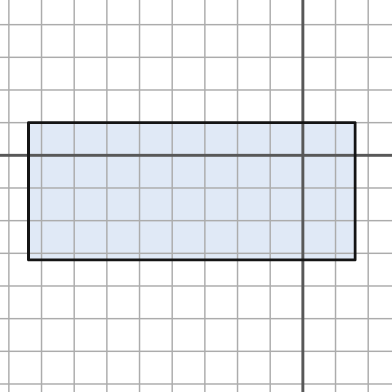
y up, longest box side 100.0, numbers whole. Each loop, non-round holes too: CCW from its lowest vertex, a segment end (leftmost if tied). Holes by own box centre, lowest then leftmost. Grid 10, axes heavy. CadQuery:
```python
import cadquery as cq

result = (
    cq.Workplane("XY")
    .moveTo(-84.0, -32.0)
    .lineTo(16.0, -32.0)
    .lineTo(16.0, 10.0)
    .lineTo(-84.0, 10.0)
    .close()
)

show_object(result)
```